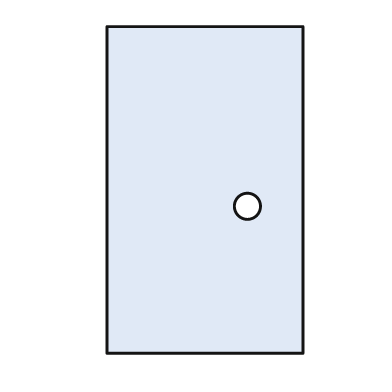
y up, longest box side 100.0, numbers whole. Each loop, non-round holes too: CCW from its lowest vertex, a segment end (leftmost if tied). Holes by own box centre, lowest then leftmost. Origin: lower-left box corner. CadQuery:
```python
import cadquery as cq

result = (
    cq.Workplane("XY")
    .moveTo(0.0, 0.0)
    .lineTo(60.0, 0.0)
    .lineTo(60.0, 100.0)
    .lineTo(0.0, 100.0)
    .close()
    .moveTo(43.0, 45.0)
    .circle(4.0)
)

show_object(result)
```